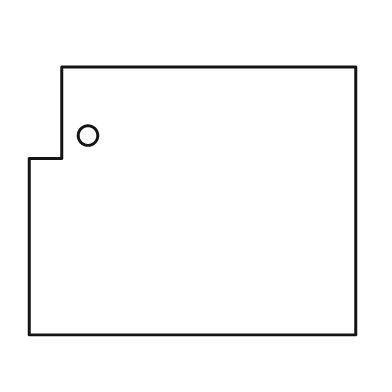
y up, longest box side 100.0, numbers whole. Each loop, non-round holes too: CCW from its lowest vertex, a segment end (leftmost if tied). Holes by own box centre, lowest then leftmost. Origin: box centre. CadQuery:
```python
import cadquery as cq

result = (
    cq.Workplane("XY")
    .moveTo(-50.0, -41.0)
    .lineTo(50.0, -41.0)
    .lineTo(50.0, 41.0)
    .lineTo(-40.0, 41.0)
    .lineTo(-40.0, 13.0)
    .lineTo(-50.0, 13.0)
    .close()
    .moveTo(-32.0, 20.0)
    .circle(3.0)
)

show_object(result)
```